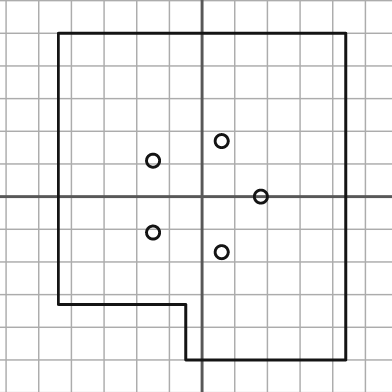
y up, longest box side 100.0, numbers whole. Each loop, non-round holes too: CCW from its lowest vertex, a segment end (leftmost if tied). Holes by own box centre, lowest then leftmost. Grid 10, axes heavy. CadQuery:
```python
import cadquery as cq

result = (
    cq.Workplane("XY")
    .moveTo(-5.0, -50.0)
    .lineTo(44.0, -50.0)
    .lineTo(44.0, 50.0)
    .lineTo(-44.0, 50.0)
    .lineTo(-44.0, -33.0)
    .lineTo(-5.0, -33.0)
    .close()
    .moveTo(6.0, -17.0)
    .circle(2.0)
    .moveTo(-15.0, -11.0)
    .circle(2.0)
    .moveTo(18.0, 0.0)
    .circle(2.0)
    .moveTo(-15.0, 11.0)
    .circle(2.0)
    .moveTo(6.0, 17.0)
    .circle(2.0)
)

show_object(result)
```